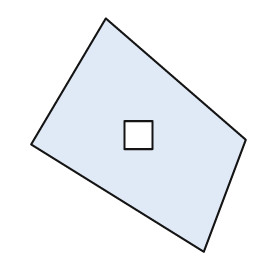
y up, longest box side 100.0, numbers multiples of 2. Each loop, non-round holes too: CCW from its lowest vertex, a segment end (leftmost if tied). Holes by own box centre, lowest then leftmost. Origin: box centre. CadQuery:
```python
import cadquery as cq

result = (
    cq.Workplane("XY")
    .moveTo(28.0, -50.0)
    .lineTo(46.0, -2.0)
    .lineTo(-14.0, 50.0)
    .lineTo(-46.0, -4.0)
    .close()
    .moveTo(-6.0, -6.0)
    .lineTo(6.0, -6.0)
    .lineTo(6.0, 6.0)
    .lineTo(-6.0, 6.0)
    .close()
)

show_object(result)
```